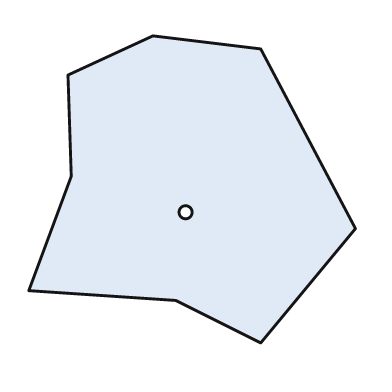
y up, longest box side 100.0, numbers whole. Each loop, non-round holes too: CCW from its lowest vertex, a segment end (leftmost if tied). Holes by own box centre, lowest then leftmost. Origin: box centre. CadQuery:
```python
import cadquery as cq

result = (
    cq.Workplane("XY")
    .moveTo(21.0, -47.0)
    .lineTo(50.0, -12.0)
    .lineTo(21.0, 43.0)
    .lineTo(-12.0, 47.0)
    .lineTo(-38.0, 35.0)
    .lineTo(-37.0, 4.0)
    .lineTo(-50.0, -31.0)
    .lineTo(-5.0, -34.0)
    .close()
    .moveTo(-2.0, -7.0)
    .circle(2.0)
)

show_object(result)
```